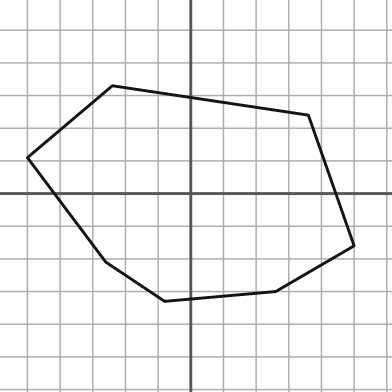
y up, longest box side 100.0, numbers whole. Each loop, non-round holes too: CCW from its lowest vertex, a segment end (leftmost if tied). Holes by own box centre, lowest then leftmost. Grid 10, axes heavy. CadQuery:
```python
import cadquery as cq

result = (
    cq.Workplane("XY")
    .moveTo(-8.0, -33.0)
    .lineTo(26.0, -30.0)
    .lineTo(50.0, -16.0)
    .lineTo(36.0, 24.0)
    .lineTo(-24.0, 33.0)
    .lineTo(-50.0, 11.0)
    .lineTo(-26.0, -21.0)
    .close()
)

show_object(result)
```